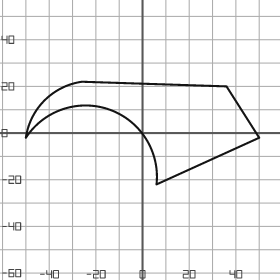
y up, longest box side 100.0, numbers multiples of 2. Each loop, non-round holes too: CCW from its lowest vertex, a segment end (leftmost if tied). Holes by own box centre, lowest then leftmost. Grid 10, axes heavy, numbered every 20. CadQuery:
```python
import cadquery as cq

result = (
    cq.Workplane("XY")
    .moveTo(6.0, -22.0)
    .lineTo(50.0, -2.0)
    .lineTo(36.0, 20.0)
    .lineTo(-26.0, 22.0)
    .threePointArc((-42.0, 14.0), (-50.0, -2.0))
    .threePointArc((-14.0, 10.0), (6.0, -22.0))
    .close()
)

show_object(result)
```